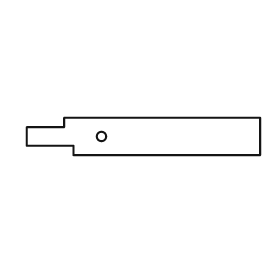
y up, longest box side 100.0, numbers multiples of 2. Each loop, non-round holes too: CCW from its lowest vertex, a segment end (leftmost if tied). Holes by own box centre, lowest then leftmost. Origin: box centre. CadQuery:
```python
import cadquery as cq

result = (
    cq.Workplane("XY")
    .moveTo(-30.0, -8.0)
    .lineTo(50.0, -8.0)
    .lineTo(50.0, 8.0)
    .lineTo(-34.0, 8.0)
    .lineTo(-34.0, 4.0)
    .lineTo(-50.0, 4.0)
    .lineTo(-50.0, -4.0)
    .lineTo(-30.0, -4.0)
    .close()
    .moveTo(-18.0, 0.0)
    .circle(2.0)
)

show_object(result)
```